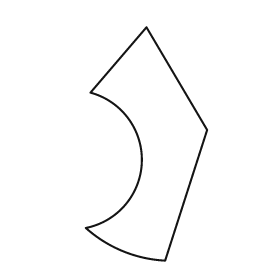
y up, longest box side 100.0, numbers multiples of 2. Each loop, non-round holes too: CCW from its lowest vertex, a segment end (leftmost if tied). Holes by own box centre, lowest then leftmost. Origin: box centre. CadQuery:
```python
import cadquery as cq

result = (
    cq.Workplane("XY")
    .moveTo(8.0, -50.0)
    .lineTo(26.0, 6.0)
    .lineTo(0.0, 50.0)
    .lineTo(-24.0, 22.0)
    .threePointArc((-2.0, -8.0), (-26.0, -36.0))
    .threePointArc((-10.0, -46.0), (8.0, -50.0))
    .close()
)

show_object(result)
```